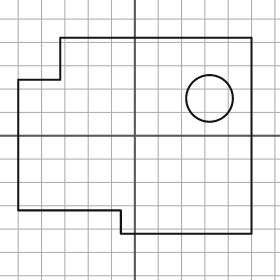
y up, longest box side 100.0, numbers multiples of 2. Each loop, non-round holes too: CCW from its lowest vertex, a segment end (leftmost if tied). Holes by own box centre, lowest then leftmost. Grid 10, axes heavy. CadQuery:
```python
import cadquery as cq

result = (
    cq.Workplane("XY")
    .moveTo(-6.0, -42.0)
    .lineTo(50.0, -42.0)
    .lineTo(50.0, 42.0)
    .lineTo(-32.0, 42.0)
    .lineTo(-32.0, 24.0)
    .lineTo(-50.0, 24.0)
    .lineTo(-50.0, -32.0)
    .lineTo(-6.0, -32.0)
    .close()
    .moveTo(32.0, 16.0)
    .circle(10.0)
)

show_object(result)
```